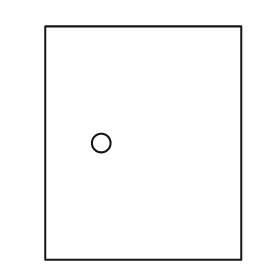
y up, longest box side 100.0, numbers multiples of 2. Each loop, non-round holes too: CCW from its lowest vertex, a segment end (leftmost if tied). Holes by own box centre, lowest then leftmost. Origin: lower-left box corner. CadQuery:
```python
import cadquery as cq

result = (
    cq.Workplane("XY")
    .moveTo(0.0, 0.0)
    .lineTo(84.0, 0.0)
    .lineTo(84.0, 100.0)
    .lineTo(0.0, 100.0)
    .close()
    .moveTo(24.0, 50.0)
    .circle(4.0)
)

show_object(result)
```